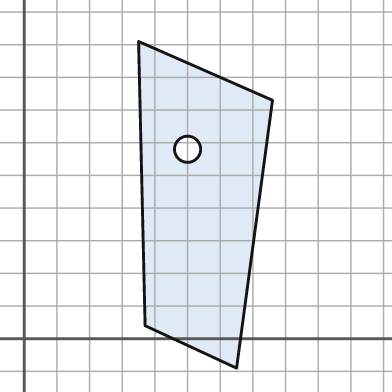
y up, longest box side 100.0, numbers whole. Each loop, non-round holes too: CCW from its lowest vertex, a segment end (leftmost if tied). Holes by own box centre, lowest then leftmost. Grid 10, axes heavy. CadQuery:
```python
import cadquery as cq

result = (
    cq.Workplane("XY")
    .moveTo(65.0, -9.0)
    .lineTo(76.0, 73.0)
    .lineTo(35.0, 91.0)
    .lineTo(37.0, 4.0)
    .close()
    .moveTo(50.0, 58.0)
    .circle(4.0)
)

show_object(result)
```